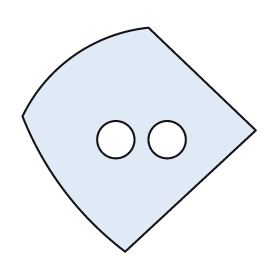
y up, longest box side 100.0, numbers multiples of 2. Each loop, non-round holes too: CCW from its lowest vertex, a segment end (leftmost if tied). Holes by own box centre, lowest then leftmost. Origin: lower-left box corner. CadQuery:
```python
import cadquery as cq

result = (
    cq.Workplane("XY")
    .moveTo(44.0, 0.0)
    .lineTo(100.0, 52.0)
    .lineTo(54.0, 96.0)
    .threePointArc((22.0, 84.0), (0.0, 58.0))
    .threePointArc((18.0, 26.0), (44.0, 0.0))
    .close()
    .moveTo(40.0, 48.0)
    .circle(8.0)
    .moveTo(62.0, 48.0)
    .circle(8.0)
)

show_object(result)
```